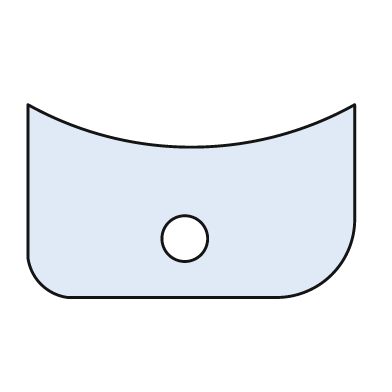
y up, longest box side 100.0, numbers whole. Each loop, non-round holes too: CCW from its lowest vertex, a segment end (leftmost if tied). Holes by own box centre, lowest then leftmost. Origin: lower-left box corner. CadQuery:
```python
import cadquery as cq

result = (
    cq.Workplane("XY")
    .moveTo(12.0, 0.0)
    .lineTo(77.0, 0.0)
    .threePointArc((93.0, 7.0), (100.0, 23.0))
    .lineTo(100.0, 59.0)
    .threePointArc((50.0, 46.0), (0.0, 59.0))
    .lineTo(0.0, 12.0)
    .threePointArc((4.0, 4.0), (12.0, 0.0))
    .close()
    .moveTo(48.0, 18.0)
    .circle(7.0)
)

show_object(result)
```